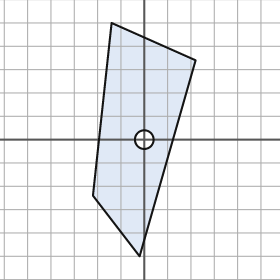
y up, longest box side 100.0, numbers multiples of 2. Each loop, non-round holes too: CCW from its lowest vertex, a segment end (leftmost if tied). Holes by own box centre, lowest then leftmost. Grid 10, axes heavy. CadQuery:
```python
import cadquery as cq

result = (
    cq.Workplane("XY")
    .moveTo(-2.0, -50.0)
    .lineTo(22.0, 34.0)
    .lineTo(-14.0, 50.0)
    .lineTo(-22.0, -24.0)
    .close()
    .moveTo(0.0, 0.0)
    .circle(4.0)
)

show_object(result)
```